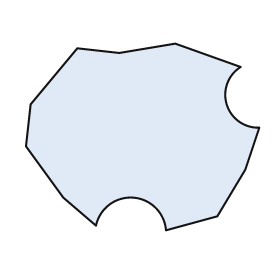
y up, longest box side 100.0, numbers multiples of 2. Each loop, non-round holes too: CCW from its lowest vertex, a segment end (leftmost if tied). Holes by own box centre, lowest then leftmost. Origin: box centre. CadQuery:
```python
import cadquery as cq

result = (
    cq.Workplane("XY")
    .moveTo(10.0, -40.0)
    .lineTo(32.0, -34.0)
    .lineTo(44.0, -14.0)
    .lineTo(50.0, 4.0)
    .threePointArc((36.0, 14.0), (42.0, 30.0))
    .lineTo(14.0, 40.0)
    .lineTo(-10.0, 36.0)
    .lineTo(-28.0, 38.0)
    .lineTo(-48.0, 14.0)
    .lineTo(-50.0, -4.0)
    .lineTo(-34.0, -26.0)
    .lineTo(-20.0, -38.0)
    .threePointArc((-4.0, -26.0), (10.0, -40.0))
    .close()
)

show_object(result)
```